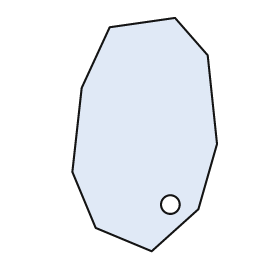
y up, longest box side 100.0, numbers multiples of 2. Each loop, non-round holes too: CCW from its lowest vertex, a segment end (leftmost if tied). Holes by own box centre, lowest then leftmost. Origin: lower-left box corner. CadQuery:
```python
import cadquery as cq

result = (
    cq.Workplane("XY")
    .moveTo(34.0, 0.0)
    .lineTo(54.0, 18.0)
    .lineTo(62.0, 46.0)
    .lineTo(58.0, 84.0)
    .lineTo(44.0, 100.0)
    .lineTo(16.0, 96.0)
    .lineTo(4.0, 70.0)
    .lineTo(0.0, 34.0)
    .lineTo(10.0, 10.0)
    .close()
    .moveTo(42.0, 20.0)
    .circle(4.0)
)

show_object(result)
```